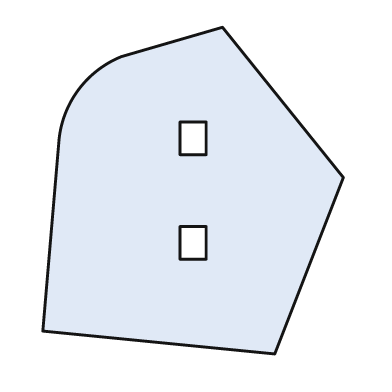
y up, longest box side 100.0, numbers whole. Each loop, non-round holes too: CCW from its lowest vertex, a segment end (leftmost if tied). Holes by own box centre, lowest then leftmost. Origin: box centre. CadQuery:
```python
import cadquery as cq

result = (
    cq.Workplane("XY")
    .moveTo(25.0, -50.0)
    .lineTo(46.0, 4.0)
    .lineTo(9.0, 50.0)
    .lineTo(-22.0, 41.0)
    .threePointArc((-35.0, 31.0), (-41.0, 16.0))
    .lineTo(-46.0, -43.0)
    .close()
    .moveTo(-4.0, -21.0)
    .lineTo(4.0, -21.0)
    .lineTo(4.0, -11.0)
    .lineTo(-4.0, -11.0)
    .close()
    .moveTo(-4.0, 11.0)
    .lineTo(4.0, 11.0)
    .lineTo(4.0, 21.0)
    .lineTo(-4.0, 21.0)
    .close()
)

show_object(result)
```